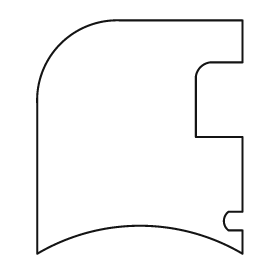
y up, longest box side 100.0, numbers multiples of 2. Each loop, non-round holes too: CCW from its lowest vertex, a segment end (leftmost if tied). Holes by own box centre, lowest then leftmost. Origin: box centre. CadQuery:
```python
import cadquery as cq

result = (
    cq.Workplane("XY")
    .moveTo(-44.0, -50.0)
    .threePointArc((0.0, -38.0), (44.0, -50.0))
    .lineTo(44.0, -40.0)
    .lineTo(38.0, -40.0)
    .threePointArc((36.0, -36.0), (38.0, -32.0))
    .lineTo(44.0, -32.0)
    .lineTo(44.0, 0.0)
    .lineTo(24.0, 0.0)
    .lineTo(24.0, 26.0)
    .threePointArc((26.0, 30.0), (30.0, 32.0))
    .lineTo(44.0, 32.0)
    .lineTo(44.0, 50.0)
    .lineTo(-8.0, 50.0)
    .threePointArc((-34.0, 40.0), (-44.0, 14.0))
    .close()
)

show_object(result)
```